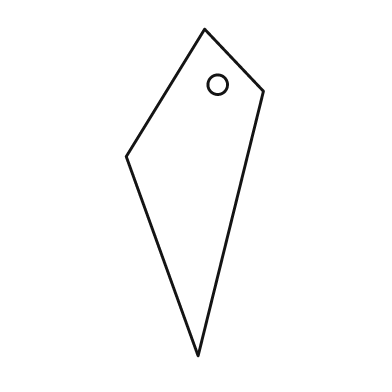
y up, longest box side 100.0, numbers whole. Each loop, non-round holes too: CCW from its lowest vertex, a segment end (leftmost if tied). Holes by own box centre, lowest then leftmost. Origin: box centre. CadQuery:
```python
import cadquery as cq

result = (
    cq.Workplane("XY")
    .moveTo(1.0, -50.0)
    .lineTo(21.0, 31.0)
    .lineTo(3.0, 50.0)
    .lineTo(-21.0, 11.0)
    .close()
    .moveTo(7.0, 33.0)
    .circle(3.0)
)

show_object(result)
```